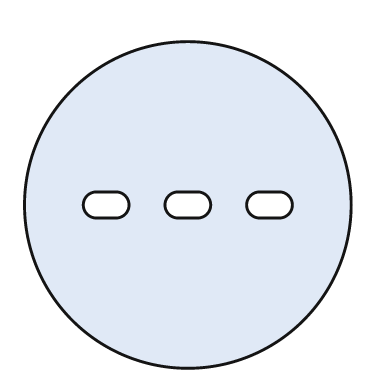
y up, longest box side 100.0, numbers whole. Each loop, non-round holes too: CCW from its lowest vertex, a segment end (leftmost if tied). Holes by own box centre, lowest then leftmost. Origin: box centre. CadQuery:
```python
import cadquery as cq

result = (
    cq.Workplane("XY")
    .moveTo(0.0, 0.0)
    .circle(50.0)
    .moveTo(-28.0, -4.0)
    .lineTo(-22.0, -4.0)
    .threePointArc((-18.0, 0.0), (-22.0, 4.0))
    .lineTo(-28.0, 4.0)
    .threePointArc((-32.0, 0.0), (-28.0, -4.0))
    .close()
    .moveTo(-3.0, -4.0)
    .lineTo(3.0, -4.0)
    .threePointArc((7.0, 0.0), (3.0, 4.0))
    .lineTo(-3.0, 4.0)
    .threePointArc((-7.0, 0.0), (-3.0, -4.0))
    .close()
    .moveTo(22.0, -4.0)
    .lineTo(28.0, -4.0)
    .threePointArc((32.0, 0.0), (28.0, 4.0))
    .lineTo(22.0, 4.0)
    .threePointArc((18.0, 0.0), (22.0, -4.0))
    .close()
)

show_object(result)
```